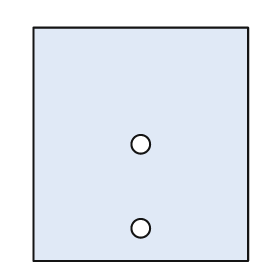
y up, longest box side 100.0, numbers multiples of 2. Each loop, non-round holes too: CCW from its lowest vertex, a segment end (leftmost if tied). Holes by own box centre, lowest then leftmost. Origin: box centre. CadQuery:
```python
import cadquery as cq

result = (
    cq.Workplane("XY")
    .moveTo(-46.0, -50.0)
    .lineTo(46.0, -50.0)
    .lineTo(46.0, 50.0)
    .lineTo(-46.0, 50.0)
    .close()
    .moveTo(0.0, -36.0)
    .circle(4.0)
    .moveTo(0.0, 0.0)
    .circle(4.0)
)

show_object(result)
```